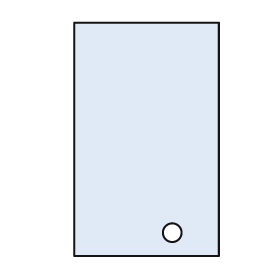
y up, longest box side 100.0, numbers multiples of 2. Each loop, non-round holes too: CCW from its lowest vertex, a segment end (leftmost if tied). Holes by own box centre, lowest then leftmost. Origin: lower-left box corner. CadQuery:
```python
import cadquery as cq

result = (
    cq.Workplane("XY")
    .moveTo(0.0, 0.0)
    .lineTo(62.0, 0.0)
    .lineTo(62.0, 100.0)
    .lineTo(0.0, 100.0)
    .close()
    .moveTo(42.0, 10.0)
    .circle(4.0)
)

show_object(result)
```